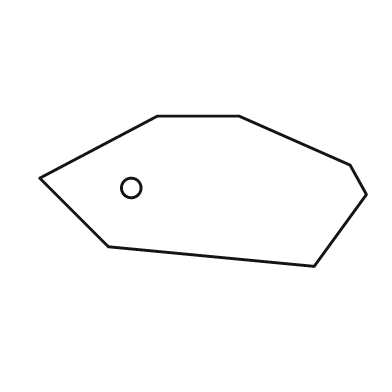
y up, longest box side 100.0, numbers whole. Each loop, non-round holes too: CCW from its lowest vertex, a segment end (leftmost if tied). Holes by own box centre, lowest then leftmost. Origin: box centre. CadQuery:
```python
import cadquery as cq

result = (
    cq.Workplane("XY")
    .moveTo(34.0, -23.0)
    .lineTo(50.0, -1.0)
    .lineTo(45.0, 8.0)
    .lineTo(11.0, 23.0)
    .lineTo(-14.0, 23.0)
    .lineTo(-50.0, 4.0)
    .lineTo(-29.0, -17.0)
    .close()
    .moveTo(-22.0, 1.0)
    .circle(3.0)
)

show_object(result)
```